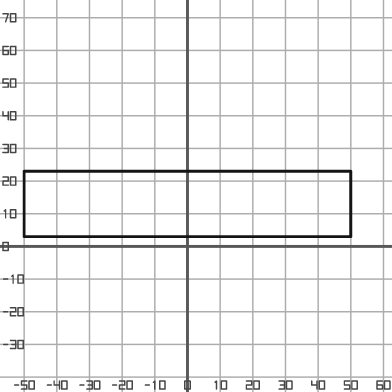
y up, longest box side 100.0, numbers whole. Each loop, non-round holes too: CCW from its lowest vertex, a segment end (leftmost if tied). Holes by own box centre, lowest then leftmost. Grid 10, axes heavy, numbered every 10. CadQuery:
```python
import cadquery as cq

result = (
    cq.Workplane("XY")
    .moveTo(-50.0, 3.0)
    .lineTo(50.0, 3.0)
    .lineTo(50.0, 23.0)
    .lineTo(-50.0, 23.0)
    .close()
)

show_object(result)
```